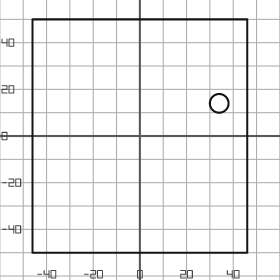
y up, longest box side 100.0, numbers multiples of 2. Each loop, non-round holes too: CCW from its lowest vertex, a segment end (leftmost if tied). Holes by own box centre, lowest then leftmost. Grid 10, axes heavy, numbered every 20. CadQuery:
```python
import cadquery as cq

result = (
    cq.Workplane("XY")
    .moveTo(-46.0, -50.0)
    .lineTo(46.0, -50.0)
    .lineTo(46.0, 50.0)
    .lineTo(-46.0, 50.0)
    .close()
    .moveTo(34.0, 14.0)
    .circle(4.0)
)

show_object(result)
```